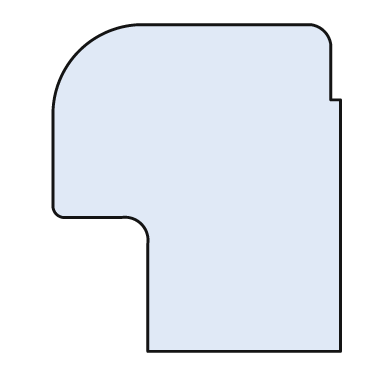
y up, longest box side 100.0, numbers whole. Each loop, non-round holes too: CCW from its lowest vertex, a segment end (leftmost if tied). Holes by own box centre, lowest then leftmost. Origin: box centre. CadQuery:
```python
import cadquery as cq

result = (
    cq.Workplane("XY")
    .moveTo(-15.0, -50.0)
    .lineTo(44.0, -50.0)
    .lineTo(44.0, 27.0)
    .lineTo(41.0, 27.0)
    .lineTo(41.0, 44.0)
    .threePointArc((39.0, 48.0), (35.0, 50.0))
    .lineTo(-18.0, 50.0)
    .threePointArc((-36.0, 42.0), (-44.0, 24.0))
    .lineTo(-44.0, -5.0)
    .threePointArc((-43.0, -8.0), (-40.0, -9.0))
    .lineTo(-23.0, -9.0)
    .threePointArc((-17.0, -11.0), (-15.0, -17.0))
    .close()
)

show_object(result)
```